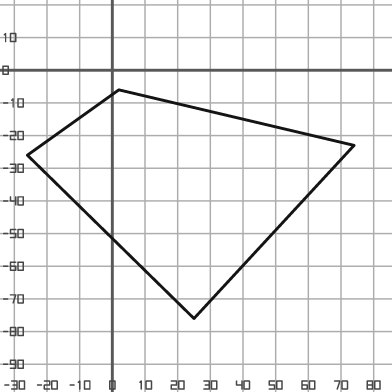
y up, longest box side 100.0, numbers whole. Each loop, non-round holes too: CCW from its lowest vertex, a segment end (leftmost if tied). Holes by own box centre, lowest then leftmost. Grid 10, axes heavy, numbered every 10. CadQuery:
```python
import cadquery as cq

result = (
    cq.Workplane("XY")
    .moveTo(25.0, -76.0)
    .lineTo(74.0, -23.0)
    .lineTo(2.0, -6.0)
    .lineTo(-26.0, -26.0)
    .close()
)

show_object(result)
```